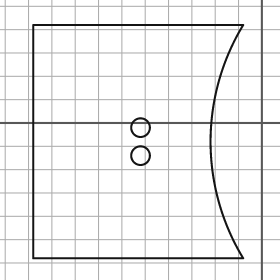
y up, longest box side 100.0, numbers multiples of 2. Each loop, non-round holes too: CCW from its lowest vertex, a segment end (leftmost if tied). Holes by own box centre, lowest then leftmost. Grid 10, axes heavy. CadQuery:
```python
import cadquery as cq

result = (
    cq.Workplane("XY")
    .moveTo(-98.0, -58.0)
    .lineTo(-8.0, -58.0)
    .threePointArc((-22.0, -8.0), (-8.0, 42.0))
    .lineTo(-98.0, 42.0)
    .close()
    .moveTo(-52.0, -14.0)
    .circle(4.0)
    .moveTo(-52.0, -2.0)
    .circle(4.0)
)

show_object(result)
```